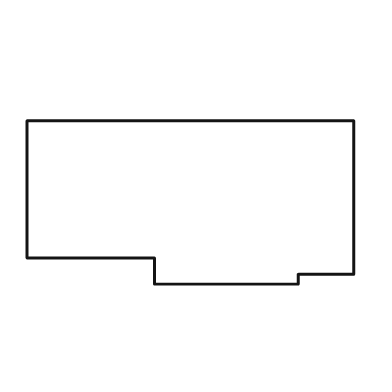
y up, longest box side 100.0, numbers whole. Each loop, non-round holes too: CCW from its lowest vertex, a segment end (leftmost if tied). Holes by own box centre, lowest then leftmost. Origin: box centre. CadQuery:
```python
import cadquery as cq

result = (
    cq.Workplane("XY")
    .moveTo(-11.0, -25.0)
    .lineTo(33.0, -25.0)
    .lineTo(33.0, -22.0)
    .lineTo(50.0, -22.0)
    .lineTo(50.0, 25.0)
    .lineTo(-50.0, 25.0)
    .lineTo(-50.0, -17.0)
    .lineTo(-11.0, -17.0)
    .close()
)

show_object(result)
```